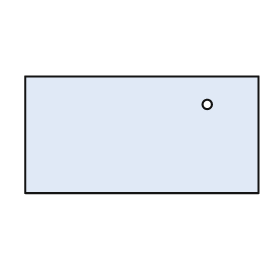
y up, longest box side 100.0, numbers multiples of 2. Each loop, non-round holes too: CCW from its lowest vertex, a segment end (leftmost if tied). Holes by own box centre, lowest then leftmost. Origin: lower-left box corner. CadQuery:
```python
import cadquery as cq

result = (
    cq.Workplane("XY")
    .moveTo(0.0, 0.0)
    .lineTo(100.0, 0.0)
    .lineTo(100.0, 50.0)
    .lineTo(0.0, 50.0)
    .close()
    .moveTo(78.0, 38.0)
    .circle(2.0)
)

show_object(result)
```